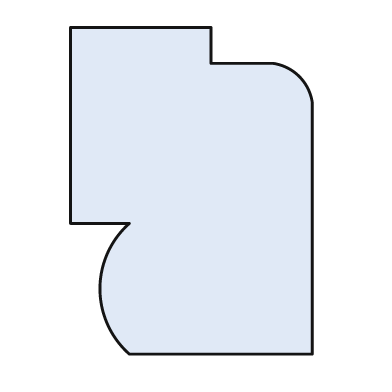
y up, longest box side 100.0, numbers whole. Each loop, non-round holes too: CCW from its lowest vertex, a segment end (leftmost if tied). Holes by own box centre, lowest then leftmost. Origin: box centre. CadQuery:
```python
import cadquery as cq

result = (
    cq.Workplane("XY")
    .moveTo(-19.0, -50.0)
    .lineTo(37.0, -50.0)
    .lineTo(37.0, 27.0)
    .threePointArc((33.0, 35.0), (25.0, 39.0))
    .lineTo(6.0, 39.0)
    .lineTo(6.0, 50.0)
    .lineTo(-37.0, 50.0)
    .lineTo(-37.0, -10.0)
    .lineTo(-19.0, -10.0)
    .threePointArc((-28.0, -30.0), (-19.0, -50.0))
    .close()
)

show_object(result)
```